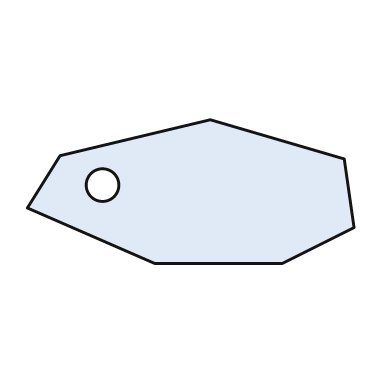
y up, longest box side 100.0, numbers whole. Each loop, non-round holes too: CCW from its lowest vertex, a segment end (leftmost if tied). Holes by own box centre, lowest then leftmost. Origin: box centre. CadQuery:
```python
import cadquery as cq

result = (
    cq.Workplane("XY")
    .moveTo(-11.0, -22.0)
    .lineTo(28.0, -22.0)
    .lineTo(50.0, -11.0)
    .lineTo(47.0, 10.0)
    .lineTo(6.0, 22.0)
    .lineTo(-40.0, 11.0)
    .lineTo(-50.0, -5.0)
    .close()
    .moveTo(-27.0, 2.0)
    .circle(5.0)
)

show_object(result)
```